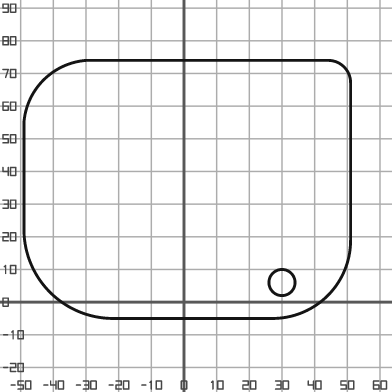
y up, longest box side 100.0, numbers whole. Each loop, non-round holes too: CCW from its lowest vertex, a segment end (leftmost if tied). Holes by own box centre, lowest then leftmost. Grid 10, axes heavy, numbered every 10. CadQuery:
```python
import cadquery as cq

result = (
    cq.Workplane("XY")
    .moveTo(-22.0, -5.0)
    .lineTo(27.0, -5.0)
    .threePointArc((44.0, 2.0), (51.0, 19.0))
    .lineTo(51.0, 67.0)
    .threePointArc((49.0, 72.0), (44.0, 74.0))
    .lineTo(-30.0, 74.0)
    .threePointArc((-43.0, 68.0), (-49.0, 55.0))
    .lineTo(-49.0, 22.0)
    .threePointArc((-41.0, 3.0), (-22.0, -5.0))
    .close()
    .moveTo(30.0, 6.0)
    .circle(4.0)
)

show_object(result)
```